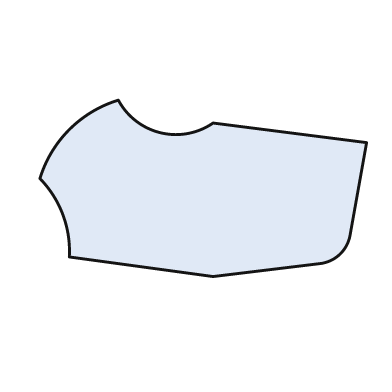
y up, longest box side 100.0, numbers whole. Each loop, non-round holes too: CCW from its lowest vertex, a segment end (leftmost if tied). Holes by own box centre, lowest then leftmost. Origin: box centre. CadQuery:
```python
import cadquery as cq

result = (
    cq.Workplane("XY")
    .moveTo(3.0, -27.0)
    .lineTo(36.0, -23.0)
    .threePointArc((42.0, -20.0), (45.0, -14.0))
    .lineTo(50.0, 14.0)
    .lineTo(3.0, 20.0)
    .threePointArc((-13.0, 17.0), (-26.0, 27.0))
    .threePointArc((-41.0, 18.0), (-50.0, 3.0))
    .threePointArc((-43.0, -8.0), (-41.0, -21.0))
    .close()
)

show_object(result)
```